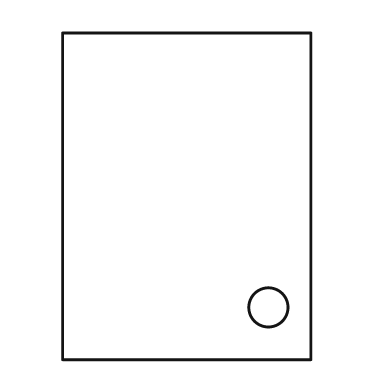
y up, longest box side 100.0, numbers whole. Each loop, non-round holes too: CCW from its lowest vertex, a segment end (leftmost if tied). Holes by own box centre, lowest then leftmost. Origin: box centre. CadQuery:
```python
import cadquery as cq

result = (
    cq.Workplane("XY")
    .moveTo(-38.0, -50.0)
    .lineTo(38.0, -50.0)
    .lineTo(38.0, 50.0)
    .lineTo(-38.0, 50.0)
    .close()
    .moveTo(25.0, -34.0)
    .circle(6.0)
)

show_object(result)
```